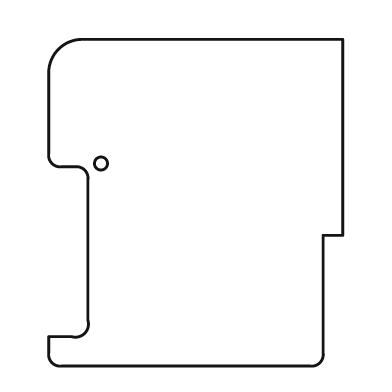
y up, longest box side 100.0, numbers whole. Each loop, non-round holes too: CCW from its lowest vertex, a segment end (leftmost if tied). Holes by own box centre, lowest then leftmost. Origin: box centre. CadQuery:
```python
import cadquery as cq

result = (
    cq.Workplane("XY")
    .moveTo(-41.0, -50.0)
    .lineTo(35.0, -50.0)
    .threePointArc((38.0, -49.0), (39.0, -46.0))
    .lineTo(39.0, -10.0)
    .lineTo(45.0, -10.0)
    .lineTo(45.0, 50.0)
    .lineTo(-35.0, 50.0)
    .threePointArc((-42.0, 47.0), (-45.0, 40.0))
    .lineTo(-45.0, 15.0)
    .threePointArc((-44.0, 12.0), (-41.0, 11.0))
    .lineTo(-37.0, 11.0)
    .threePointArc((-34.0, 10.0), (-33.0, 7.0))
    .lineTo(-33.0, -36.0)
    .threePointArc((-34.0, -40.0), (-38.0, -41.0))
    .lineTo(-45.0, -41.0)
    .lineTo(-45.0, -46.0)
    .threePointArc((-44.0, -49.0), (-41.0, -50.0))
    .close()
    .moveTo(-29.0, 12.0)
    .circle(2.0)
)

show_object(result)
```